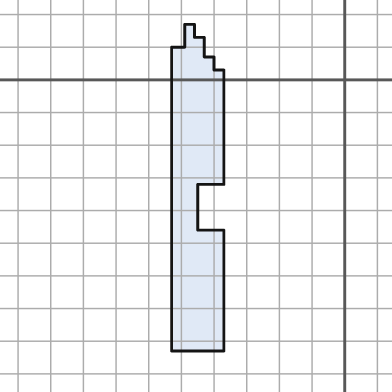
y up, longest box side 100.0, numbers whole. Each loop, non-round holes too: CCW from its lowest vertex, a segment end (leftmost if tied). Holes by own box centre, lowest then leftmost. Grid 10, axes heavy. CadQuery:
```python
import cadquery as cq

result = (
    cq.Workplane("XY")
    .moveTo(-53.0, -83.0)
    .lineTo(-37.0, -83.0)
    .lineTo(-37.0, -46.0)
    .lineTo(-45.0, -46.0)
    .lineTo(-45.0, -32.0)
    .lineTo(-37.0, -32.0)
    .lineTo(-37.0, 3.0)
    .lineTo(-40.0, 3.0)
    .lineTo(-40.0, 7.0)
    .lineTo(-43.0, 7.0)
    .lineTo(-43.0, 13.0)
    .lineTo(-46.0, 13.0)
    .lineTo(-46.0, 17.0)
    .lineTo(-49.0, 17.0)
    .lineTo(-49.0, 10.0)
    .lineTo(-53.0, 10.0)
    .close()
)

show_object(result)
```